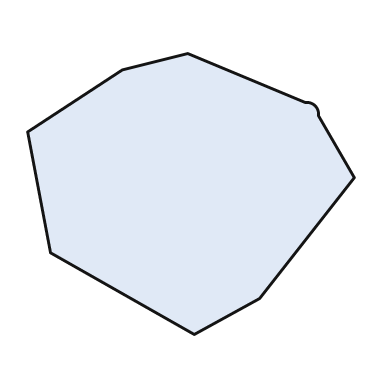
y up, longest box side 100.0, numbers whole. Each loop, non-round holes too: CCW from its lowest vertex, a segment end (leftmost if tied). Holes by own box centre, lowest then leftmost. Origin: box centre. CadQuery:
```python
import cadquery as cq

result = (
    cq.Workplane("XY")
    .moveTo(1.0, -43.0)
    .lineTo(21.0, -32.0)
    .lineTo(50.0, 5.0)
    .lineTo(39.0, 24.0)
    .threePointArc((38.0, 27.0), (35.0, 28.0))
    .lineTo(-1.0, 43.0)
    .lineTo(-21.0, 38.0)
    .lineTo(-50.0, 19.0)
    .lineTo(-43.0, -18.0)
    .close()
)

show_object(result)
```